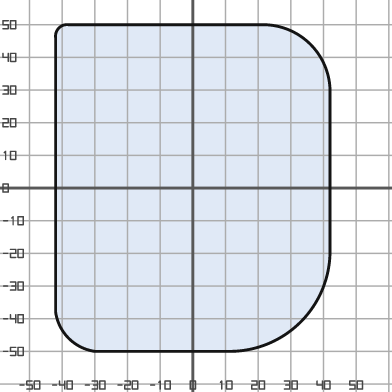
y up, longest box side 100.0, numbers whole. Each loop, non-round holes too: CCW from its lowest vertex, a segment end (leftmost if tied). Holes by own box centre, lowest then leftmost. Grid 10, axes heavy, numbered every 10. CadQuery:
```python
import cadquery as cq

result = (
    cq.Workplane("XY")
    .moveTo(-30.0, -50.0)
    .lineTo(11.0, -50.0)
    .threePointArc((33.0, -41.0), (42.0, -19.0))
    .lineTo(42.0, 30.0)
    .threePointArc((36.0, 44.0), (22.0, 50.0))
    .lineTo(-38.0, 50.0)
    .threePointArc((-41.0, 49.0), (-42.0, 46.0))
    .lineTo(-42.0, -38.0)
    .threePointArc((-38.0, -46.0), (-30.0, -50.0))
    .close()
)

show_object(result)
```